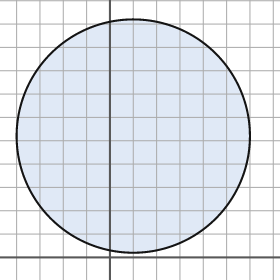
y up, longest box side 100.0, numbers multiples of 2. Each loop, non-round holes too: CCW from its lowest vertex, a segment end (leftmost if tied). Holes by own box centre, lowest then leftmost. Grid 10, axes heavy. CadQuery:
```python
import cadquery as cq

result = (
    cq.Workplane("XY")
    .moveTo(10.0, 52.0)
    .circle(50.0)
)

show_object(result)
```